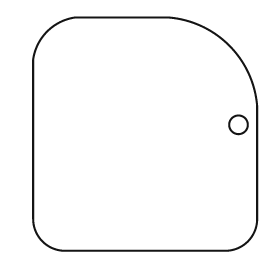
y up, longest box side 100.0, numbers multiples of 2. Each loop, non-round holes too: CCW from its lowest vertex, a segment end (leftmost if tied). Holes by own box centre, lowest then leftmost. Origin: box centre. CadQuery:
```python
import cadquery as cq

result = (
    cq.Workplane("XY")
    .moveTo(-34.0, -50.0)
    .lineTo(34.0, -50.0)
    .threePointArc((44.0, -46.0), (48.0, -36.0))
    .lineTo(48.0, 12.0)
    .threePointArc((36.0, 38.0), (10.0, 50.0))
    .lineTo(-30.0, 50.0)
    .threePointArc((-42.0, 44.0), (-48.0, 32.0))
    .lineTo(-48.0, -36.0)
    .threePointArc((-44.0, -46.0), (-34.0, -50.0))
    .close()
    .moveTo(40.0, 4.0)
    .circle(4.0)
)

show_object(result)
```